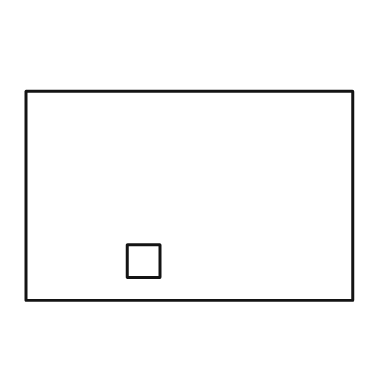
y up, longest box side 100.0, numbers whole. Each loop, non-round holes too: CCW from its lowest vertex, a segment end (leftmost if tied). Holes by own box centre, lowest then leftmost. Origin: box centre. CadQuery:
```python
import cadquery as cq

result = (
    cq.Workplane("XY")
    .moveTo(-50.0, -32.0)
    .lineTo(50.0, -32.0)
    .lineTo(50.0, 32.0)
    .lineTo(-50.0, 32.0)
    .close()
    .moveTo(-19.0, -25.0)
    .lineTo(-9.0, -25.0)
    .lineTo(-9.0, -15.0)
    .lineTo(-19.0, -15.0)
    .close()
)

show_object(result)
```